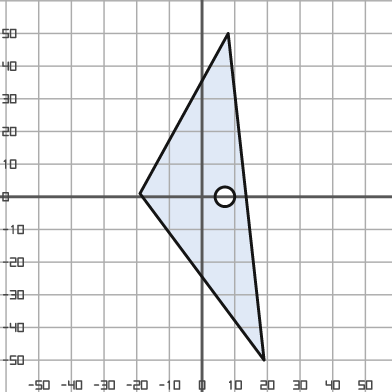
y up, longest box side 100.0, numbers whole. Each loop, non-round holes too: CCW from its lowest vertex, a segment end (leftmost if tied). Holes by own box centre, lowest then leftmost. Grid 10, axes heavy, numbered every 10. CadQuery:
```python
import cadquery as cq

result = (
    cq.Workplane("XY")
    .moveTo(19.0, -50.0)
    .lineTo(8.0, 50.0)
    .lineTo(-19.0, 1.0)
    .close()
    .moveTo(7.0, 0.0)
    .circle(3.0)
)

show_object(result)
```